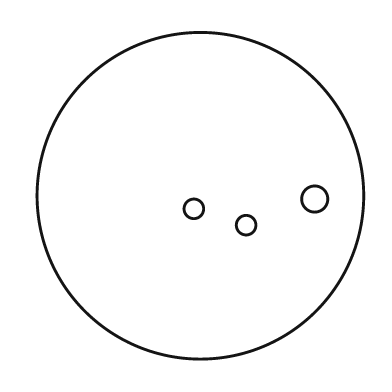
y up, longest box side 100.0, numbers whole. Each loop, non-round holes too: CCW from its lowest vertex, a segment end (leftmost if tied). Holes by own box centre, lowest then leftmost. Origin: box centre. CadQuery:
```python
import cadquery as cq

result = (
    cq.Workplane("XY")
    .moveTo(0.0, 0.0)
    .circle(50.0)
    .moveTo(14.0, -9.0)
    .circle(3.0)
    .moveTo(-2.0, -4.0)
    .circle(3.0)
    .moveTo(35.0, -1.0)
    .circle(4.0)
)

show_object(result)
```